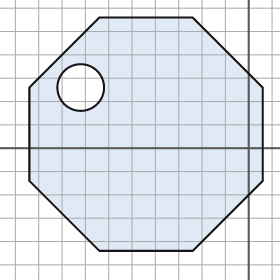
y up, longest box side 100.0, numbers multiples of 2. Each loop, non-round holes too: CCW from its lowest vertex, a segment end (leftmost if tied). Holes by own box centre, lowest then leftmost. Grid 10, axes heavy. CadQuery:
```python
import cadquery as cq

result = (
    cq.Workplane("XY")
    .moveTo(-64.0, -44.0)
    .lineTo(-24.0, -44.0)
    .lineTo(6.0, -14.0)
    .lineTo(6.0, 26.0)
    .lineTo(-24.0, 56.0)
    .lineTo(-64.0, 56.0)
    .lineTo(-94.0, 26.0)
    .lineTo(-94.0, -14.0)
    .close()
    .moveTo(-72.0, 26.0)
    .circle(10.0)
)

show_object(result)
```